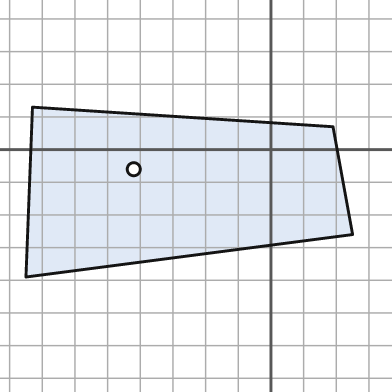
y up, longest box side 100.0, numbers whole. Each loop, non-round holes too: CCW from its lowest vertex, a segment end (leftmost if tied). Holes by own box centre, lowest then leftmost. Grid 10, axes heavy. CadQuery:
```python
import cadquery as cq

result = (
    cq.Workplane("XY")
    .moveTo(-75.0, -39.0)
    .lineTo(25.0, -26.0)
    .lineTo(19.0, 7.0)
    .lineTo(-73.0, 13.0)
    .close()
    .moveTo(-42.0, -6.0)
    .circle(2.0)
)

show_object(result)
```